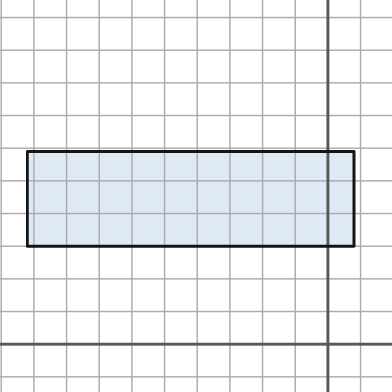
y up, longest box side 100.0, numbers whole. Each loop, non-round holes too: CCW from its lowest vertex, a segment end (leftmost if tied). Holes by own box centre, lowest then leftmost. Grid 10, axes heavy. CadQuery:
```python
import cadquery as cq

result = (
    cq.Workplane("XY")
    .moveTo(-92.0, 30.0)
    .lineTo(8.0, 30.0)
    .lineTo(8.0, 59.0)
    .lineTo(-92.0, 59.0)
    .close()
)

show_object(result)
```